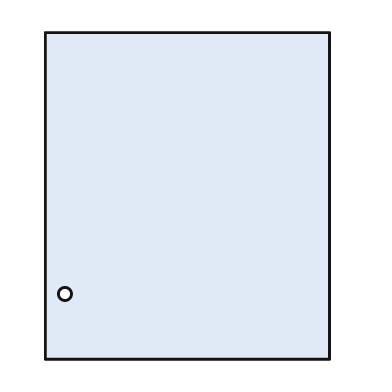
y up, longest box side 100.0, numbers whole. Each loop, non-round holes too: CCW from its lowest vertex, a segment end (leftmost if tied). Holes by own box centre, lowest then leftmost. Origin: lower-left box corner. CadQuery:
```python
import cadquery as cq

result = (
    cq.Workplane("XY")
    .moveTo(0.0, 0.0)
    .lineTo(87.0, 0.0)
    .lineTo(87.0, 100.0)
    .lineTo(0.0, 100.0)
    .close()
    .moveTo(6.0, 20.0)
    .circle(2.0)
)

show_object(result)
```